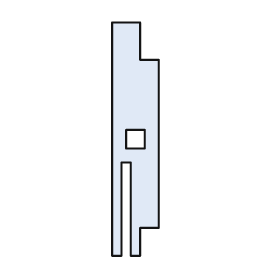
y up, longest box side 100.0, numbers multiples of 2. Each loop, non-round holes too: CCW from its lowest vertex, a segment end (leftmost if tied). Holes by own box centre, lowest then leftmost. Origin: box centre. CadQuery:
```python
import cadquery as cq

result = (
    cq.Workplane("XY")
    .moveTo(-10.0, -50.0)
    .lineTo(-6.0, -50.0)
    .lineTo(-6.0, -10.0)
    .lineTo(-2.0, -10.0)
    .lineTo(-2.0, -50.0)
    .lineTo(2.0, -50.0)
    .lineTo(2.0, -38.0)
    .lineTo(10.0, -38.0)
    .lineTo(10.0, 34.0)
    .lineTo(2.0, 34.0)
    .lineTo(2.0, 50.0)
    .lineTo(-10.0, 50.0)
    .close()
    .moveTo(-4.0, -4.0)
    .lineTo(4.0, -4.0)
    .lineTo(4.0, 4.0)
    .lineTo(-4.0, 4.0)
    .close()
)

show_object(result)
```